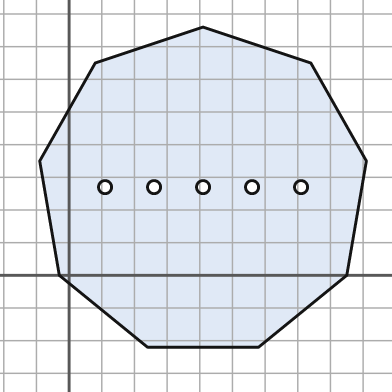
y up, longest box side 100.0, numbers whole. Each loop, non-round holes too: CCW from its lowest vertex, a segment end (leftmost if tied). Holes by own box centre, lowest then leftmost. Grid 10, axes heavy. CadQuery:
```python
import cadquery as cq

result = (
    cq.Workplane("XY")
    .moveTo(24.0, -22.0)
    .lineTo(58.0, -22.0)
    .lineTo(85.0, 0.0)
    .lineTo(91.0, 35.0)
    .lineTo(74.0, 65.0)
    .lineTo(41.0, 76.0)
    .lineTo(8.0, 65.0)
    .lineTo(-9.0, 35.0)
    .lineTo(-3.0, 0.0)
    .close()
    .moveTo(11.0, 27.0)
    .circle(2.0)
    .moveTo(26.0, 27.0)
    .circle(2.0)
    .moveTo(41.0, 27.0)
    .circle(2.0)
    .moveTo(56.0, 27.0)
    .circle(2.0)
    .moveTo(71.0, 27.0)
    .circle(2.0)
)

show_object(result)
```